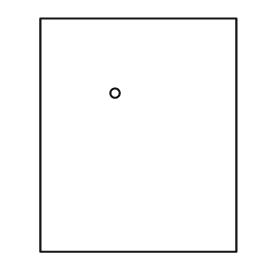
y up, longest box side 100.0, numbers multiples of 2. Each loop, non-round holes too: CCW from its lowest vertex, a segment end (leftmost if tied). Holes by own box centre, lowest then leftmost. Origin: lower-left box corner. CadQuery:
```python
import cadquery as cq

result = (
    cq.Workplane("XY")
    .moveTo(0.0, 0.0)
    .lineTo(84.0, 0.0)
    .lineTo(84.0, 100.0)
    .lineTo(0.0, 100.0)
    .close()
    .moveTo(32.0, 68.0)
    .circle(2.0)
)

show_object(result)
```